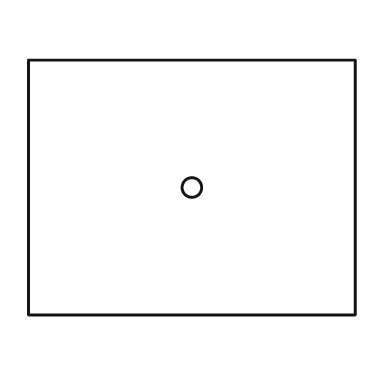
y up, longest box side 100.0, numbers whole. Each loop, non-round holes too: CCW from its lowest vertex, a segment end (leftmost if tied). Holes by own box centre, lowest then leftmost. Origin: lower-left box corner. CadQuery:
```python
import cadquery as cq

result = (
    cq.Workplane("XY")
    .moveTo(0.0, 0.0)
    .lineTo(100.0, 0.0)
    .lineTo(100.0, 78.0)
    .lineTo(0.0, 78.0)
    .close()
    .moveTo(50.0, 39.0)
    .circle(3.0)
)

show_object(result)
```